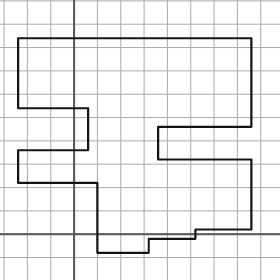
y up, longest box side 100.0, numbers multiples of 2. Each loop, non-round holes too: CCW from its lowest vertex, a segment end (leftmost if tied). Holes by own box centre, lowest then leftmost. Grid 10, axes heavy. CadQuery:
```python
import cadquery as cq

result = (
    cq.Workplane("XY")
    .moveTo(10.0, -8.0)
    .lineTo(32.0, -8.0)
    .lineTo(32.0, -2.0)
    .lineTo(52.0, -2.0)
    .lineTo(52.0, 2.0)
    .lineTo(76.0, 2.0)
    .lineTo(76.0, 32.0)
    .lineTo(36.0, 32.0)
    .lineTo(36.0, 46.0)
    .lineTo(76.0, 46.0)
    .lineTo(76.0, 84.0)
    .lineTo(-24.0, 84.0)
    .lineTo(-24.0, 54.0)
    .lineTo(6.0, 54.0)
    .lineTo(6.0, 36.0)
    .lineTo(-24.0, 36.0)
    .lineTo(-24.0, 22.0)
    .lineTo(10.0, 22.0)
    .close()
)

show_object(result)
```